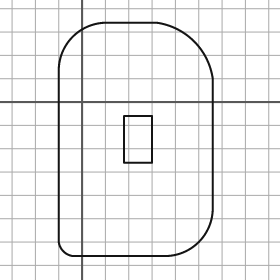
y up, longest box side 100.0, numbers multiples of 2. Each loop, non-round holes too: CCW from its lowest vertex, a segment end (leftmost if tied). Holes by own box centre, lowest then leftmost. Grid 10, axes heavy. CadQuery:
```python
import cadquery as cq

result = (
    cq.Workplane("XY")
    .moveTo(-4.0, -66.0)
    .lineTo(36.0, -66.0)
    .threePointArc((50.0, -60.0), (56.0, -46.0))
    .lineTo(56.0, 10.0)
    .threePointArc((48.0, 26.0), (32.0, 34.0))
    .lineTo(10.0, 34.0)
    .threePointArc((-4.0, 28.0), (-10.0, 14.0))
    .lineTo(-10.0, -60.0)
    .threePointArc((-8.0, -64.0), (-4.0, -66.0))
    .close()
    .moveTo(18.0, -26.0)
    .lineTo(30.0, -26.0)
    .lineTo(30.0, -6.0)
    .lineTo(18.0, -6.0)
    .close()
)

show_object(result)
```